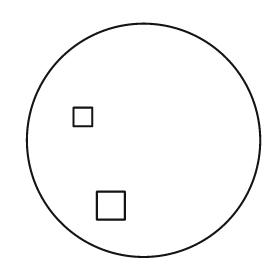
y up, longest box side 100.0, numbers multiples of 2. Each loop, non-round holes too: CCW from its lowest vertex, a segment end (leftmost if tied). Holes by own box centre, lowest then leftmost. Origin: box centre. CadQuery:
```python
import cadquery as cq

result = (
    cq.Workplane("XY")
    .moveTo(0.0, 0.0)
    .circle(50.0)
    .moveTo(-20.0, -34.0)
    .lineTo(-8.0, -34.0)
    .lineTo(-8.0, -22.0)
    .lineTo(-20.0, -22.0)
    .close()
    .moveTo(-30.0, 6.0)
    .lineTo(-22.0, 6.0)
    .lineTo(-22.0, 14.0)
    .lineTo(-30.0, 14.0)
    .close()
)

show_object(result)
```